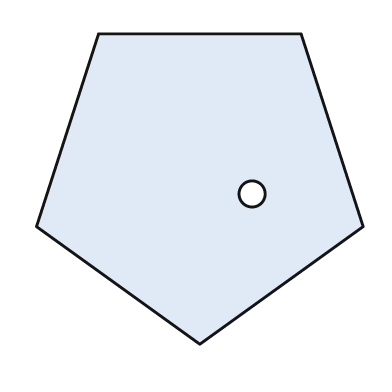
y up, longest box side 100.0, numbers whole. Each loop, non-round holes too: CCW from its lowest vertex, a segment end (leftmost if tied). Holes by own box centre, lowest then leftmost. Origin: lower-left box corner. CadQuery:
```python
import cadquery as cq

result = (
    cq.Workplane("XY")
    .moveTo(50.0, 0.0)
    .lineTo(100.0, 36.0)
    .lineTo(81.0, 95.0)
    .lineTo(19.0, 95.0)
    .lineTo(0.0, 36.0)
    .close()
    .moveTo(66.0, 46.0)
    .circle(4.0)
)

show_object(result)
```